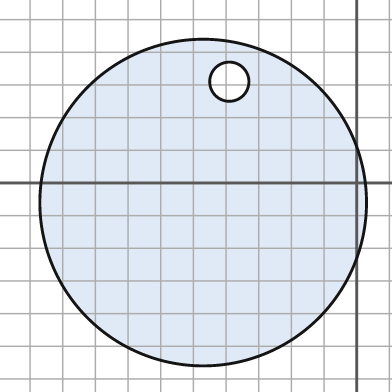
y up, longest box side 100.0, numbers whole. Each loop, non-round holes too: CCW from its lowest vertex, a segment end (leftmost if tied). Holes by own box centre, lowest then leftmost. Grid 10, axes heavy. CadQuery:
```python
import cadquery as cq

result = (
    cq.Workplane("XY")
    .moveTo(-47.0, -6.0)
    .circle(50.0)
    .moveTo(-39.0, 31.0)
    .circle(6.0)
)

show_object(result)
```